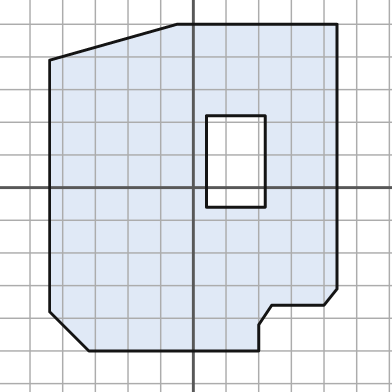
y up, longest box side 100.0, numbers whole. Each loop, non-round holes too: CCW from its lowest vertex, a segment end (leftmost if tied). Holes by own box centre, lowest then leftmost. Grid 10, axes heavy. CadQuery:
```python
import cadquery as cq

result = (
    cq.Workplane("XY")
    .moveTo(-32.0, -50.0)
    .lineTo(20.0, -50.0)
    .lineTo(20.0, -42.0)
    .lineTo(24.0, -36.0)
    .lineTo(40.0, -36.0)
    .lineTo(44.0, -31.0)
    .lineTo(44.0, 50.0)
    .lineTo(-5.0, 50.0)
    .lineTo(-44.0, 39.0)
    .lineTo(-44.0, -38.0)
    .close()
    .moveTo(4.0, -6.0)
    .lineTo(22.0, -6.0)
    .lineTo(22.0, 22.0)
    .lineTo(4.0, 22.0)
    .close()
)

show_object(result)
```